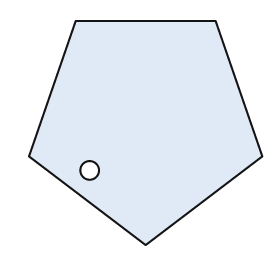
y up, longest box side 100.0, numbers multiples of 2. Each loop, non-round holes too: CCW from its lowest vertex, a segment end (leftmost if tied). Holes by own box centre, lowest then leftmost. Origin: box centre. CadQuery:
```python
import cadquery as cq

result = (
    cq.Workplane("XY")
    .moveTo(0.0, -48.0)
    .lineTo(50.0, -10.0)
    .lineTo(30.0, 48.0)
    .lineTo(-30.0, 48.0)
    .lineTo(-50.0, -10.0)
    .close()
    .moveTo(-24.0, -16.0)
    .circle(4.0)
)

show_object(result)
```